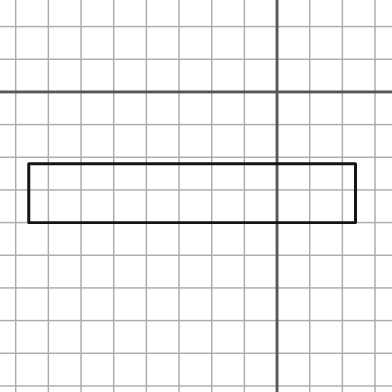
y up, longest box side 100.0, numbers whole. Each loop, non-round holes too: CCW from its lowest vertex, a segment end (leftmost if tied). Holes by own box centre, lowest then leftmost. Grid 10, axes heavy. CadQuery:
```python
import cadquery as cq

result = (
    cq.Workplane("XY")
    .moveTo(-76.0, -40.0)
    .lineTo(24.0, -40.0)
    .lineTo(24.0, -22.0)
    .lineTo(-76.0, -22.0)
    .close()
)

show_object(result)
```